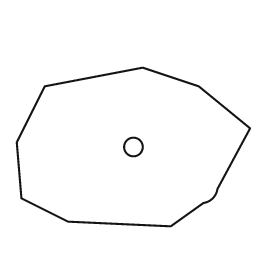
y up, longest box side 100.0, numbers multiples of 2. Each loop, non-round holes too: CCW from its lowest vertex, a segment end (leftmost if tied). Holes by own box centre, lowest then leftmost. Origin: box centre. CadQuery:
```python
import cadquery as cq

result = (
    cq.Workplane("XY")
    .moveTo(16.0, -34.0)
    .lineTo(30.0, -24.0)
    .threePointArc((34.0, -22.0), (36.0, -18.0))
    .lineTo(50.0, 8.0)
    .lineTo(28.0, 26.0)
    .lineTo(4.0, 34.0)
    .lineTo(-38.0, 26.0)
    .lineTo(-50.0, 2.0)
    .lineTo(-48.0, -22.0)
    .lineTo(-28.0, -32.0)
    .close()
    .moveTo(0.0, 0.0)
    .circle(4.0)
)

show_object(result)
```